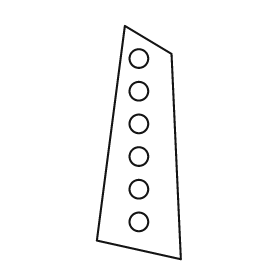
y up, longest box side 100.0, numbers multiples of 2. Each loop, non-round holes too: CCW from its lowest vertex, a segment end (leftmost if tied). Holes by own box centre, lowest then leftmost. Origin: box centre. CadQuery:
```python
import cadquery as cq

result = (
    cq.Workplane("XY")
    .moveTo(18.0, -50.0)
    .lineTo(14.0, 38.0)
    .lineTo(-6.0, 50.0)
    .lineTo(-18.0, -42.0)
    .close()
    .moveTo(0.0, -34.0)
    .circle(4.0)
    .moveTo(0.0, -20.0)
    .circle(4.0)
    .moveTo(0.0, -6.0)
    .circle(4.0)
    .moveTo(0.0, 8.0)
    .circle(4.0)
    .moveTo(0.0, 22.0)
    .circle(4.0)
    .moveTo(0.0, 36.0)
    .circle(4.0)
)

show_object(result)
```